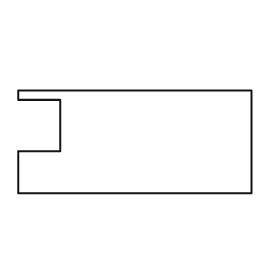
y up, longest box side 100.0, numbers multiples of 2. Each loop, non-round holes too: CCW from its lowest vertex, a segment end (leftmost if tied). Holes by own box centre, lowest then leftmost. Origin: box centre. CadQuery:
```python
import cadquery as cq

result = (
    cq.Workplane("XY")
    .moveTo(-50.0, -22.0)
    .lineTo(50.0, -22.0)
    .lineTo(50.0, 22.0)
    .lineTo(-50.0, 22.0)
    .lineTo(-50.0, 18.0)
    .lineTo(-32.0, 18.0)
    .lineTo(-32.0, -4.0)
    .lineTo(-50.0, -4.0)
    .close()
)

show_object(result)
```